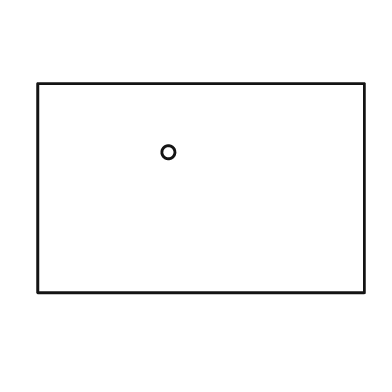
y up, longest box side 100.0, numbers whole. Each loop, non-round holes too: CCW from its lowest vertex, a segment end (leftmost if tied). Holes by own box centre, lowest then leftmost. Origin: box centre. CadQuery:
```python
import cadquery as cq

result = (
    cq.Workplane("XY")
    .moveTo(-50.0, -32.0)
    .lineTo(50.0, -32.0)
    .lineTo(50.0, 32.0)
    .lineTo(-50.0, 32.0)
    .close()
    .moveTo(-10.0, 11.0)
    .circle(2.0)
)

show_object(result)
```